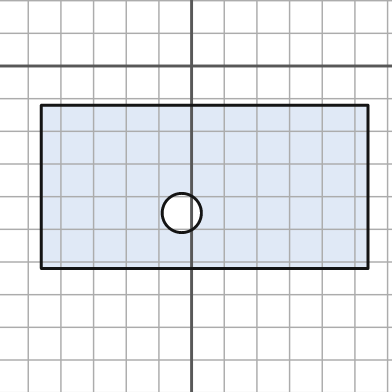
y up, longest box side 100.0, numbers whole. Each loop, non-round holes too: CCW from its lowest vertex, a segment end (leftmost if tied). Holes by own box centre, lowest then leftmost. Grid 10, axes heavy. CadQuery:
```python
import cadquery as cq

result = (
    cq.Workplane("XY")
    .moveTo(-46.0, -62.0)
    .lineTo(54.0, -62.0)
    .lineTo(54.0, -12.0)
    .lineTo(-46.0, -12.0)
    .close()
    .moveTo(-3.0, -45.0)
    .circle(6.0)
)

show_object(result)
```